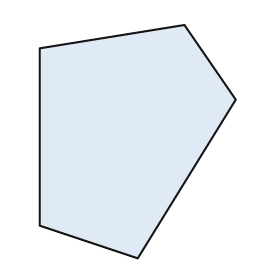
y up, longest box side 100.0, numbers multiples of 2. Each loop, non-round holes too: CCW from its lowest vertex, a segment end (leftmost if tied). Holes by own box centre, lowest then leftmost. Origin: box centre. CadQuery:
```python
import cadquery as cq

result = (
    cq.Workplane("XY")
    .moveTo(0.0, -50.0)
    .lineTo(42.0, 18.0)
    .lineTo(20.0, 50.0)
    .lineTo(-42.0, 40.0)
    .lineTo(-42.0, -36.0)
    .close()
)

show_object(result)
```